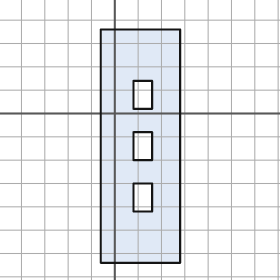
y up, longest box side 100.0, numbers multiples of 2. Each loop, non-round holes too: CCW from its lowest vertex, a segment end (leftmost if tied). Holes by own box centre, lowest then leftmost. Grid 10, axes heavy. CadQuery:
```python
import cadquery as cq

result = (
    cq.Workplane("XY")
    .moveTo(-6.0, -64.0)
    .lineTo(28.0, -64.0)
    .lineTo(28.0, 36.0)
    .lineTo(-6.0, 36.0)
    .close()
    .moveTo(8.0, -42.0)
    .lineTo(16.0, -42.0)
    .lineTo(16.0, -30.0)
    .lineTo(8.0, -30.0)
    .close()
    .moveTo(8.0, -20.0)
    .lineTo(16.0, -20.0)
    .lineTo(16.0, -8.0)
    .lineTo(8.0, -8.0)
    .close()
    .moveTo(8.0, 2.0)
    .lineTo(16.0, 2.0)
    .lineTo(16.0, 14.0)
    .lineTo(8.0, 14.0)
    .close()
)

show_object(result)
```